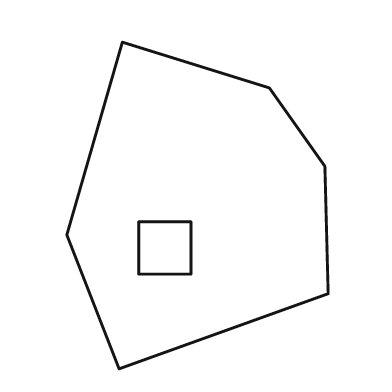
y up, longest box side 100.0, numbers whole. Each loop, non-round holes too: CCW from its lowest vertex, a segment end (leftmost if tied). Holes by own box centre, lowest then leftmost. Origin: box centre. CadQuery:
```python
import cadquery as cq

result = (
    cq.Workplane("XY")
    .moveTo(-24.0, -50.0)
    .lineTo(40.0, -27.0)
    .lineTo(39.0, 12.0)
    .lineTo(22.0, 36.0)
    .lineTo(-23.0, 50.0)
    .lineTo(-40.0, -9.0)
    .close()
    .moveTo(-18.0, -21.0)
    .lineTo(-2.0, -21.0)
    .lineTo(-2.0, -5.0)
    .lineTo(-18.0, -5.0)
    .close()
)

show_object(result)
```